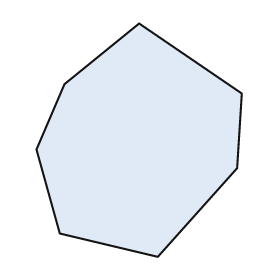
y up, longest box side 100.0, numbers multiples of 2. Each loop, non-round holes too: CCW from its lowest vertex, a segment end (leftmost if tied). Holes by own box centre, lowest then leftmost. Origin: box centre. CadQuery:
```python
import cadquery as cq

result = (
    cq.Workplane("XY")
    .moveTo(8.0, -50.0)
    .lineTo(42.0, -12.0)
    .lineTo(44.0, 20.0)
    .lineTo(0.0, 50.0)
    .lineTo(-32.0, 24.0)
    .lineTo(-44.0, -4.0)
    .lineTo(-34.0, -40.0)
    .close()
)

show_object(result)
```